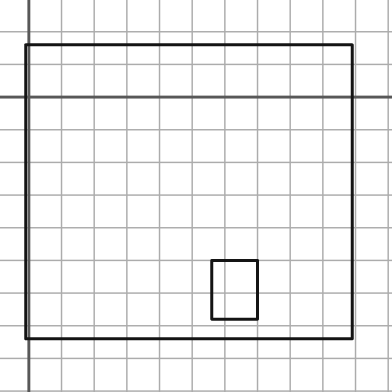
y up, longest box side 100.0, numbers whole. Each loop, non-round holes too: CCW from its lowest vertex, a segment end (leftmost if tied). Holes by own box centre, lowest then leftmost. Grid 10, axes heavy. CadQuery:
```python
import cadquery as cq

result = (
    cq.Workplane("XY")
    .moveTo(-1.0, -74.0)
    .lineTo(99.0, -74.0)
    .lineTo(99.0, 16.0)
    .lineTo(-1.0, 16.0)
    .close()
    .moveTo(56.0, -68.0)
    .lineTo(70.0, -68.0)
    .lineTo(70.0, -50.0)
    .lineTo(56.0, -50.0)
    .close()
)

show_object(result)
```